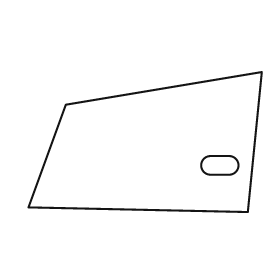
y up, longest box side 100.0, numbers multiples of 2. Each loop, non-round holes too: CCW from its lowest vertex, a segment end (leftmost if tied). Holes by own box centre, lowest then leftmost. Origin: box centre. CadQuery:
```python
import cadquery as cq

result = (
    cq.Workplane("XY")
    .moveTo(44.0, -30.0)
    .lineTo(50.0, 30.0)
    .lineTo(-34.0, 16.0)
    .lineTo(-50.0, -28.0)
    .close()
    .moveTo(28.0, -14.0)
    .lineTo(36.0, -14.0)
    .threePointArc((40.0, -10.0), (36.0, -6.0))
    .lineTo(28.0, -6.0)
    .threePointArc((24.0, -10.0), (28.0, -14.0))
    .close()
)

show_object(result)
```